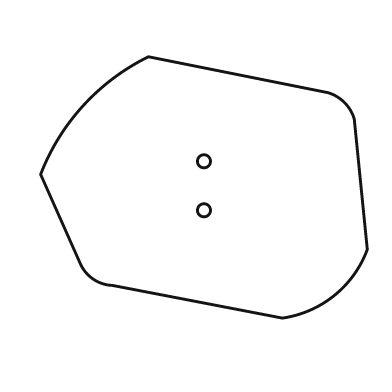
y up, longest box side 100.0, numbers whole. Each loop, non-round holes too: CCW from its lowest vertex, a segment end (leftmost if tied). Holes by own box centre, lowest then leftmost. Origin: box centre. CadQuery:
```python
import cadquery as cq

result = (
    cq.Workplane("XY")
    .moveTo(24.0, -40.0)
    .threePointArc((40.0, -33.0), (50.0, -19.0))
    .lineTo(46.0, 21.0)
    .threePointArc((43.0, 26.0), (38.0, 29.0))
    .lineTo(-17.0, 40.0)
    .threePointArc((-37.0, 25.0), (-50.0, 4.0))
    .lineTo(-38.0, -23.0)
    .threePointArc((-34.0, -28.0), (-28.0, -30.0))
    .close()
    .moveTo(0.0, -7.0)
    .circle(2.0)
    .moveTo(0.0, 8.0)
    .circle(2.0)
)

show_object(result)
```